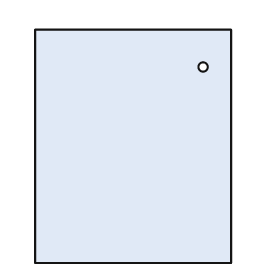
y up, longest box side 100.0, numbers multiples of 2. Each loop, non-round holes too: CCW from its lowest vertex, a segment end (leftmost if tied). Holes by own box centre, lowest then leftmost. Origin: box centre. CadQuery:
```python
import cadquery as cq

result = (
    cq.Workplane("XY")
    .moveTo(-42.0, -50.0)
    .lineTo(42.0, -50.0)
    .lineTo(42.0, 50.0)
    .lineTo(-42.0, 50.0)
    .close()
    .moveTo(30.0, 34.0)
    .circle(2.0)
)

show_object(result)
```